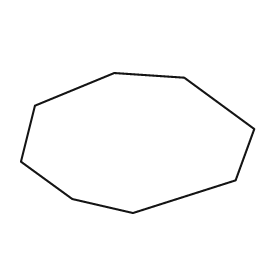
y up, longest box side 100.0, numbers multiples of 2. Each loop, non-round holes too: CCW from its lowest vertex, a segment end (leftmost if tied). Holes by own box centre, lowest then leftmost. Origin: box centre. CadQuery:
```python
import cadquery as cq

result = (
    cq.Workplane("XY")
    .moveTo(-2.0, -30.0)
    .lineTo(42.0, -16.0)
    .lineTo(50.0, 6.0)
    .lineTo(20.0, 28.0)
    .lineTo(-10.0, 30.0)
    .lineTo(-44.0, 16.0)
    .lineTo(-50.0, -8.0)
    .lineTo(-28.0, -24.0)
    .close()
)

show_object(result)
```